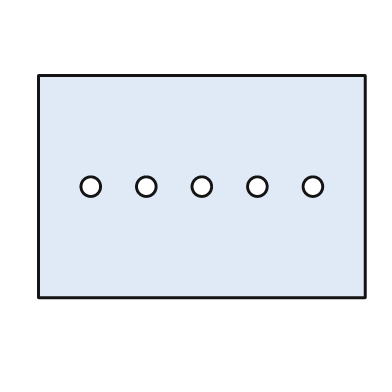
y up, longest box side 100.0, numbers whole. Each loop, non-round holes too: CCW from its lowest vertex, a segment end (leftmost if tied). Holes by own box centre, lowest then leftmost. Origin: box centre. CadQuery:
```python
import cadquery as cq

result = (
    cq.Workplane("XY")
    .moveTo(-50.0, -34.0)
    .lineTo(50.0, -34.0)
    .lineTo(50.0, 34.0)
    .lineTo(-50.0, 34.0)
    .close()
    .moveTo(-34.0, 0.0)
    .circle(3.0)
    .moveTo(-17.0, 0.0)
    .circle(3.0)
    .moveTo(0.0, 0.0)
    .circle(3.0)
    .moveTo(17.0, 0.0)
    .circle(3.0)
    .moveTo(34.0, 0.0)
    .circle(3.0)
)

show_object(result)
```